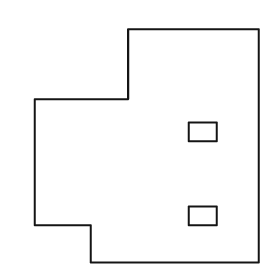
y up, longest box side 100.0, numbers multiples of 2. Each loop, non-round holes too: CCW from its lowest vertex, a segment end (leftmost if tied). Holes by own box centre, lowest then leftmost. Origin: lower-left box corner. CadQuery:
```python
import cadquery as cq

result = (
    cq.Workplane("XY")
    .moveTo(24.0, 0.0)
    .lineTo(96.0, 0.0)
    .lineTo(96.0, 100.0)
    .lineTo(40.0, 100.0)
    .lineTo(40.0, 70.0)
    .lineTo(0.0, 70.0)
    .lineTo(0.0, 16.0)
    .lineTo(24.0, 16.0)
    .close()
    .moveTo(66.0, 16.0)
    .lineTo(78.0, 16.0)
    .lineTo(78.0, 24.0)
    .lineTo(66.0, 24.0)
    .close()
    .moveTo(66.0, 52.0)
    .lineTo(78.0, 52.0)
    .lineTo(78.0, 60.0)
    .lineTo(66.0, 60.0)
    .close()
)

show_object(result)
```